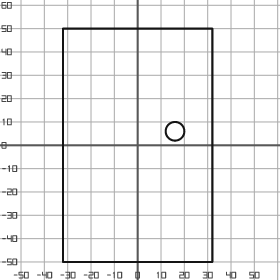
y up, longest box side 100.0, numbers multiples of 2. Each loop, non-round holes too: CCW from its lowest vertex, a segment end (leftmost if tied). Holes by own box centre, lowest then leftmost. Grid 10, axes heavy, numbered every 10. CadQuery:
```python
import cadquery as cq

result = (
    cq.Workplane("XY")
    .moveTo(-32.0, -50.0)
    .lineTo(32.0, -50.0)
    .lineTo(32.0, 50.0)
    .lineTo(-32.0, 50.0)
    .close()
    .moveTo(16.0, 6.0)
    .circle(4.0)
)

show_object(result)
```